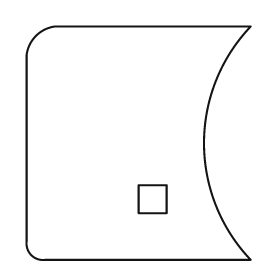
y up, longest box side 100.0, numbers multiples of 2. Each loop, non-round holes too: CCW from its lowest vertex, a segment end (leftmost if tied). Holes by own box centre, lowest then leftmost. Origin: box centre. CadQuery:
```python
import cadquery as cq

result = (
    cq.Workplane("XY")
    .moveTo(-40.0, -50.0)
    .lineTo(48.0, -50.0)
    .threePointArc((28.0, 0.0), (48.0, 50.0))
    .lineTo(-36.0, 50.0)
    .threePointArc((-44.0, 46.0), (-48.0, 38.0))
    .lineTo(-48.0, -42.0)
    .threePointArc((-46.0, -48.0), (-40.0, -50.0))
    .close()
    .moveTo(0.0, -30.0)
    .lineTo(12.0, -30.0)
    .lineTo(12.0, -18.0)
    .lineTo(0.0, -18.0)
    .close()
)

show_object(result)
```